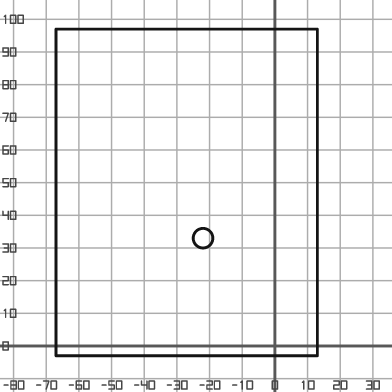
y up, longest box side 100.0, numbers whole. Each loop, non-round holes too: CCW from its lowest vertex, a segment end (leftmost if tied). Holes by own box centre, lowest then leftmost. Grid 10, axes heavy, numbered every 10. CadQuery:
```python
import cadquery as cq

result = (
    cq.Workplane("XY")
    .moveTo(-67.0, -3.0)
    .lineTo(13.0, -3.0)
    .lineTo(13.0, 97.0)
    .lineTo(-67.0, 97.0)
    .close()
    .moveTo(-22.0, 33.0)
    .circle(3.0)
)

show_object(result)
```